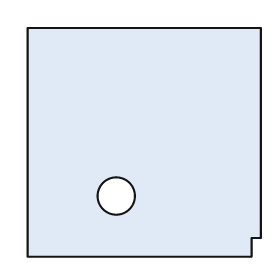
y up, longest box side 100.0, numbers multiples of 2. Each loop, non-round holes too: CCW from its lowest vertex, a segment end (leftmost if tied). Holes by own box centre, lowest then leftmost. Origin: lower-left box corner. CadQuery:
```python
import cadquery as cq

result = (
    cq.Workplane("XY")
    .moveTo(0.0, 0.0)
    .lineTo(96.0, 0.0)
    .lineTo(96.0, 8.0)
    .lineTo(100.0, 8.0)
    .lineTo(100.0, 98.0)
    .lineTo(0.0, 98.0)
    .close()
    .moveTo(38.0, 26.0)
    .circle(8.0)
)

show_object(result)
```